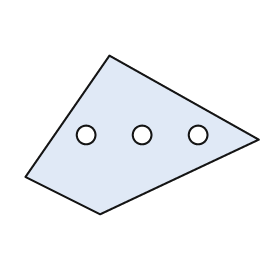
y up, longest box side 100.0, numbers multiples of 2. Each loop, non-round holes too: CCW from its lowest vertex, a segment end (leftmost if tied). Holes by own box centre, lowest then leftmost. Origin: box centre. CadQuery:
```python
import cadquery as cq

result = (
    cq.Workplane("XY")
    .moveTo(-18.0, -34.0)
    .lineTo(50.0, -2.0)
    .lineTo(-14.0, 34.0)
    .lineTo(-50.0, -18.0)
    .close()
    .moveTo(-24.0, 0.0)
    .circle(4.0)
    .moveTo(0.0, 0.0)
    .circle(4.0)
    .moveTo(24.0, 0.0)
    .circle(4.0)
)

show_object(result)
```